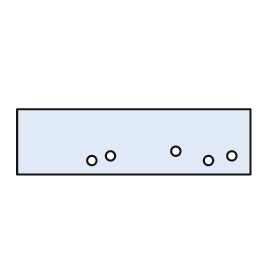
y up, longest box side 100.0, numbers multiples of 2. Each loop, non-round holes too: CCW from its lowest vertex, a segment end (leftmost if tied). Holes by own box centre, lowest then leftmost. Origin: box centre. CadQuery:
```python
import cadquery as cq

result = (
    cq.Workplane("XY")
    .moveTo(-50.0, -14.0)
    .lineTo(50.0, -14.0)
    .lineTo(50.0, 14.0)
    .lineTo(-50.0, 14.0)
    .close()
    .moveTo(-18.0, -8.0)
    .circle(2.0)
    .moveTo(32.0, -8.0)
    .circle(2.0)
    .moveTo(-10.0, -6.0)
    .circle(2.0)
    .moveTo(42.0, -6.0)
    .circle(2.0)
    .moveTo(18.0, -4.0)
    .circle(2.0)
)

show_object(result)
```